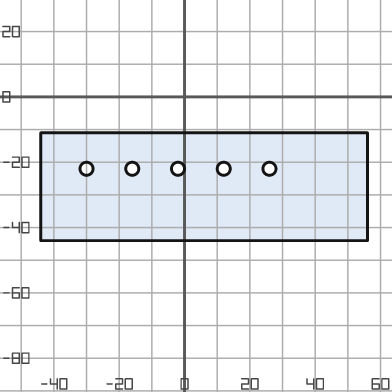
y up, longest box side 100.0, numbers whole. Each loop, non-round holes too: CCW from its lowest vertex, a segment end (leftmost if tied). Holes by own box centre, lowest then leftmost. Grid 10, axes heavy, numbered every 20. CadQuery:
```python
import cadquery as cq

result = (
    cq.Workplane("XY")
    .moveTo(-44.0, -44.0)
    .lineTo(56.0, -44.0)
    .lineTo(56.0, -11.0)
    .lineTo(-44.0, -11.0)
    .close()
    .moveTo(-30.0, -22.0)
    .circle(2.0)
    .moveTo(-16.0, -22.0)
    .circle(2.0)
    .moveTo(-2.0, -22.0)
    .circle(2.0)
    .moveTo(12.0, -22.0)
    .circle(2.0)
    .moveTo(26.0, -22.0)
    .circle(2.0)
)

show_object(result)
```